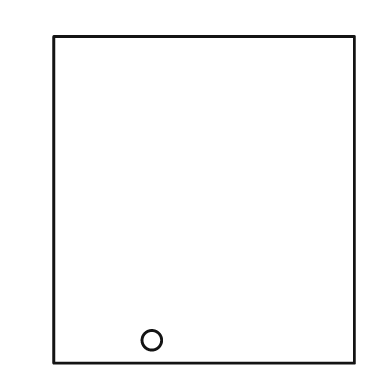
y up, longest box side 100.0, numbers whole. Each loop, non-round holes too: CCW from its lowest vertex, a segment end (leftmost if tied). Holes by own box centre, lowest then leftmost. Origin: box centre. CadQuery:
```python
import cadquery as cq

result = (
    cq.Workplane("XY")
    .moveTo(-46.0, -50.0)
    .lineTo(46.0, -50.0)
    .lineTo(46.0, 50.0)
    .lineTo(-46.0, 50.0)
    .close()
    .moveTo(-16.0, -43.0)
    .circle(3.0)
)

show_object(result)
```